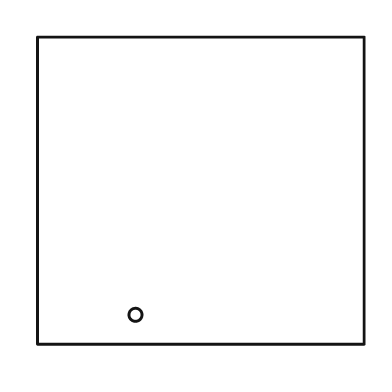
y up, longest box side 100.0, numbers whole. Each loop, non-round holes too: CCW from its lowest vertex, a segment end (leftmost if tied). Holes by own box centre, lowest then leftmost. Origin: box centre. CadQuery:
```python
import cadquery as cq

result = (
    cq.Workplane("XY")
    .moveTo(-50.0, -47.0)
    .lineTo(50.0, -47.0)
    .lineTo(50.0, 47.0)
    .lineTo(-50.0, 47.0)
    .close()
    .moveTo(-20.0, -38.0)
    .circle(2.0)
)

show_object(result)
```